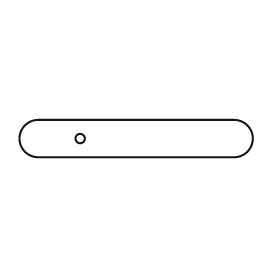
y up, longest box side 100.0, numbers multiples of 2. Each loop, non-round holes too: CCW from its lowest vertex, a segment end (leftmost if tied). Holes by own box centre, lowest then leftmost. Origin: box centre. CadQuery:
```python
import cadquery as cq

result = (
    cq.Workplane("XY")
    .moveTo(-42.0, -8.0)
    .lineTo(42.0, -8.0)
    .threePointArc((50.0, 0.0), (42.0, 8.0))
    .lineTo(-42.0, 8.0)
    .threePointArc((-50.0, 0.0), (-42.0, -8.0))
    .close()
    .moveTo(-24.0, 0.0)
    .circle(2.0)
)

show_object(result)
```